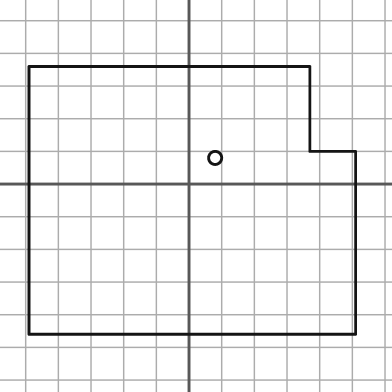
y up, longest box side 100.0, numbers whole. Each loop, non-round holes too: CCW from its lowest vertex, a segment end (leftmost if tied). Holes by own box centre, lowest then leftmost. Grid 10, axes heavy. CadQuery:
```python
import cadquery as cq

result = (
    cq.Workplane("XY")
    .moveTo(-49.0, -46.0)
    .lineTo(51.0, -46.0)
    .lineTo(51.0, 10.0)
    .lineTo(37.0, 10.0)
    .lineTo(37.0, 36.0)
    .lineTo(-49.0, 36.0)
    .close()
    .moveTo(8.0, 8.0)
    .circle(2.0)
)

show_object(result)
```